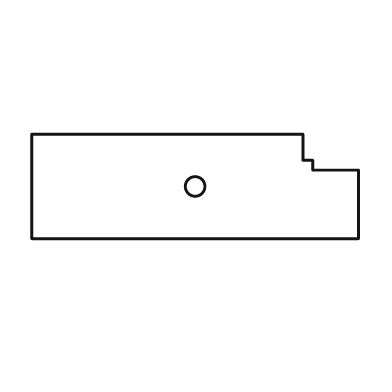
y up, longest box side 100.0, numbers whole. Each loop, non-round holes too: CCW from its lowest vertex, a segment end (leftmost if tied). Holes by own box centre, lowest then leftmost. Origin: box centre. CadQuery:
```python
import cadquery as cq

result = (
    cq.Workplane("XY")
    .moveTo(-50.0, -16.0)
    .lineTo(50.0, -16.0)
    .lineTo(50.0, 5.0)
    .lineTo(36.0, 5.0)
    .lineTo(36.0, 8.0)
    .lineTo(33.0, 8.0)
    .lineTo(33.0, 16.0)
    .lineTo(-50.0, 16.0)
    .close()
    .moveTo(0.0, 0.0)
    .circle(3.0)
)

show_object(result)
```